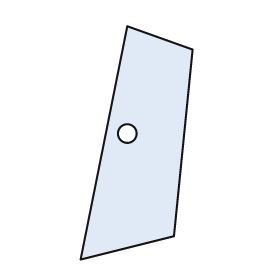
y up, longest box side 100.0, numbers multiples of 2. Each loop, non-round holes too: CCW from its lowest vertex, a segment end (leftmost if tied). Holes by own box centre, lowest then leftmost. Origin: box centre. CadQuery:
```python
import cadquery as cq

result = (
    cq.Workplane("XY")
    .moveTo(-24.0, -50.0)
    .lineTo(16.0, -40.0)
    .lineTo(24.0, 40.0)
    .lineTo(-4.0, 50.0)
    .close()
    .moveTo(-4.0, 4.0)
    .circle(4.0)
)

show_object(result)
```